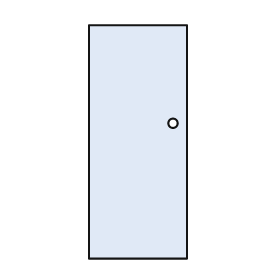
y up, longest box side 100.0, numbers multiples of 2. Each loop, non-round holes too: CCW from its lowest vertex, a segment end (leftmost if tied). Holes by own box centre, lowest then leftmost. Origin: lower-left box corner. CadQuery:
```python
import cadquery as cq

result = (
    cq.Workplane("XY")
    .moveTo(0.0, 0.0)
    .lineTo(42.0, 0.0)
    .lineTo(42.0, 100.0)
    .lineTo(0.0, 100.0)
    .close()
    .moveTo(36.0, 58.0)
    .circle(2.0)
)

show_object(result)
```